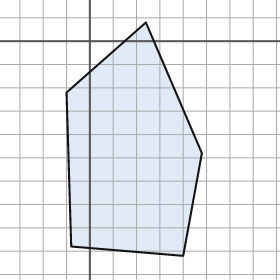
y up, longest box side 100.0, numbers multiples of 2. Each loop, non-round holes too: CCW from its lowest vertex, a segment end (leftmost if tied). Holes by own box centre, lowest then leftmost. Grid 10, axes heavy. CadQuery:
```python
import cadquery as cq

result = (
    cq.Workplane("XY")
    .moveTo(40.0, -92.0)
    .lineTo(48.0, -48.0)
    .lineTo(24.0, 8.0)
    .lineTo(-10.0, -22.0)
    .lineTo(-8.0, -88.0)
    .close()
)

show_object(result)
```